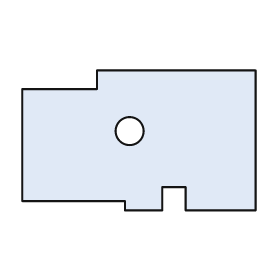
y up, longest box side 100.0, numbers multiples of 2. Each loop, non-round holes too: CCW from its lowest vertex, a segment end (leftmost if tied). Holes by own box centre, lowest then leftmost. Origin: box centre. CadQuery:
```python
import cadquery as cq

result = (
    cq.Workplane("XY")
    .moveTo(-6.0, -30.0)
    .lineTo(10.0, -30.0)
    .lineTo(10.0, -20.0)
    .lineTo(20.0, -20.0)
    .lineTo(20.0, -30.0)
    .lineTo(50.0, -30.0)
    .lineTo(50.0, 30.0)
    .lineTo(-18.0, 30.0)
    .lineTo(-18.0, 22.0)
    .lineTo(-50.0, 22.0)
    .lineTo(-50.0, -26.0)
    .lineTo(-6.0, -26.0)
    .close()
    .moveTo(-4.0, 4.0)
    .circle(6.0)
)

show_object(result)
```